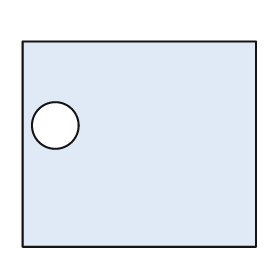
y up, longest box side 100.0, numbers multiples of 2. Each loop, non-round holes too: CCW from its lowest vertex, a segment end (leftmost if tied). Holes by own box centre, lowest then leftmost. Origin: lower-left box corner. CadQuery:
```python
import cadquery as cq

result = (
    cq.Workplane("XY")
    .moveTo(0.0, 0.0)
    .lineTo(100.0, 0.0)
    .lineTo(100.0, 88.0)
    .lineTo(0.0, 88.0)
    .close()
    .moveTo(14.0, 52.0)
    .circle(10.0)
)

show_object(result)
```